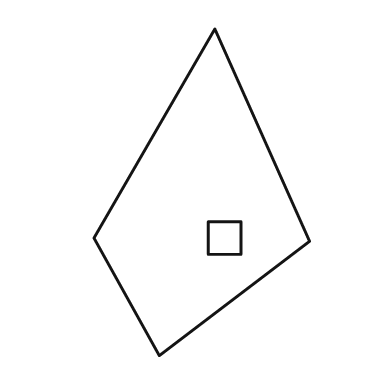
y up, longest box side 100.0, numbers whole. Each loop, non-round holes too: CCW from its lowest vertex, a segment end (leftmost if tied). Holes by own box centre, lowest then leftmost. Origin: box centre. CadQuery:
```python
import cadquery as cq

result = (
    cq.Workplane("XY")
    .moveTo(-13.0, -50.0)
    .lineTo(33.0, -15.0)
    .lineTo(4.0, 50.0)
    .lineTo(-33.0, -14.0)
    .close()
    .moveTo(2.0, -19.0)
    .lineTo(12.0, -19.0)
    .lineTo(12.0, -9.0)
    .lineTo(2.0, -9.0)
    .close()
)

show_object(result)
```